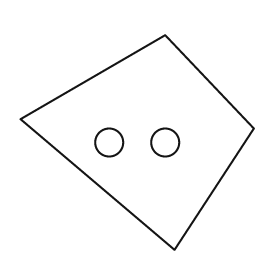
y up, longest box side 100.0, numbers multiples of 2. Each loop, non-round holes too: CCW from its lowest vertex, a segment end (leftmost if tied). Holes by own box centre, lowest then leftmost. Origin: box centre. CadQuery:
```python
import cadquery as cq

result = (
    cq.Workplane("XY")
    .moveTo(16.0, -46.0)
    .lineTo(50.0, 6.0)
    .lineTo(12.0, 46.0)
    .lineTo(-50.0, 10.0)
    .close()
    .moveTo(-12.0, 0.0)
    .circle(6.0)
    .moveTo(12.0, 0.0)
    .circle(6.0)
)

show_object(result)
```